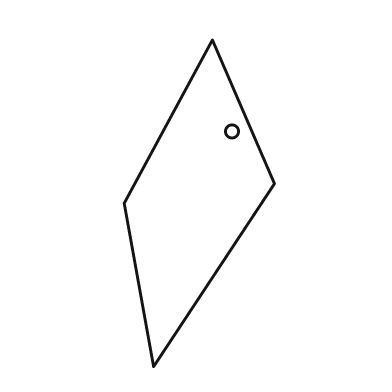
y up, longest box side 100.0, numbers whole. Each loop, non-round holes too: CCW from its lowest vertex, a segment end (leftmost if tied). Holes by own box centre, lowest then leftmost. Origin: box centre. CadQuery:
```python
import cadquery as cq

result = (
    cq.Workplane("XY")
    .moveTo(-14.0, -50.0)
    .lineTo(23.0, 6.0)
    .lineTo(4.0, 50.0)
    .lineTo(-23.0, 0.0)
    .close()
    .moveTo(10.0, 22.0)
    .circle(2.0)
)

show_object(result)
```